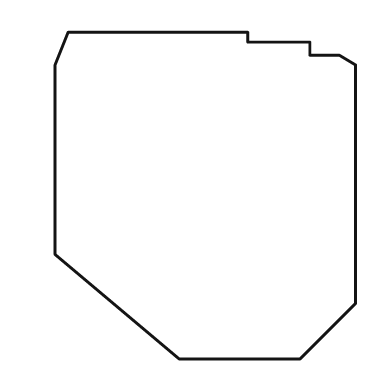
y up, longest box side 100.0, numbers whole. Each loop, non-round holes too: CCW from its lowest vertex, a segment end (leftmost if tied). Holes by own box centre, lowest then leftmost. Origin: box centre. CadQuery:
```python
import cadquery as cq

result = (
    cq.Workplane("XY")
    .moveTo(-8.0, -50.0)
    .lineTo(29.0, -50.0)
    .lineTo(46.0, -33.0)
    .lineTo(46.0, 40.0)
    .lineTo(41.0, 43.0)
    .lineTo(32.0, 43.0)
    .lineTo(32.0, 47.0)
    .lineTo(13.0, 47.0)
    .lineTo(13.0, 50.0)
    .lineTo(-42.0, 50.0)
    .lineTo(-46.0, 40.0)
    .lineTo(-46.0, -18.0)
    .close()
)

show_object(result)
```